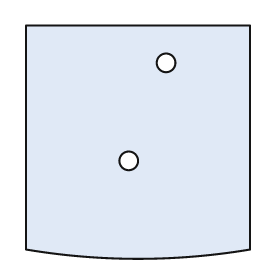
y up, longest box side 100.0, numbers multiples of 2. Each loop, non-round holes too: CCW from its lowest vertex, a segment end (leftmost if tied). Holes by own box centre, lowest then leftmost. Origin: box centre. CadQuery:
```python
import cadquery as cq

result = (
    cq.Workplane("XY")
    .moveTo(-48.0, -46.0)
    .threePointArc((0.0, -50.0), (48.0, -46.0))
    .lineTo(48.0, 50.0)
    .lineTo(-48.0, 50.0)
    .close()
    .moveTo(-4.0, -8.0)
    .circle(4.0)
    .moveTo(12.0, 34.0)
    .circle(4.0)
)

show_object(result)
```